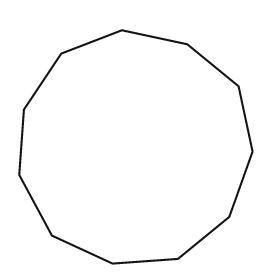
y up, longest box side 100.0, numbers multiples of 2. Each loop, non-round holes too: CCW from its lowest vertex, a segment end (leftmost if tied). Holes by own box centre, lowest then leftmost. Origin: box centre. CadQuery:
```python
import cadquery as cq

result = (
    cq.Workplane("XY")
    .moveTo(-10.0, -50.0)
    .lineTo(18.0, -48.0)
    .lineTo(40.0, -30.0)
    .lineTo(50.0, -2.0)
    .lineTo(44.0, 26.0)
    .lineTo(22.0, 44.0)
    .lineTo(-6.0, 50.0)
    .lineTo(-32.0, 40.0)
    .lineTo(-48.0, 16.0)
    .lineTo(-50.0, -12.0)
    .lineTo(-36.0, -38.0)
    .close()
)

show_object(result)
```